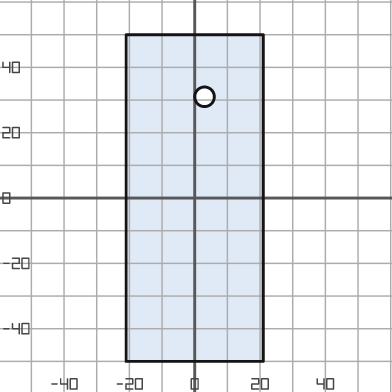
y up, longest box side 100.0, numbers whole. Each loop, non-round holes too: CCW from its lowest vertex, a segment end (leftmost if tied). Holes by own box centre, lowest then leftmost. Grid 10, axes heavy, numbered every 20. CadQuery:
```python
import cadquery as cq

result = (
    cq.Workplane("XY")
    .moveTo(-21.0, -50.0)
    .lineTo(21.0, -50.0)
    .lineTo(21.0, 50.0)
    .lineTo(-21.0, 50.0)
    .close()
    .moveTo(3.0, 31.0)
    .circle(3.0)
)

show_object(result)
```